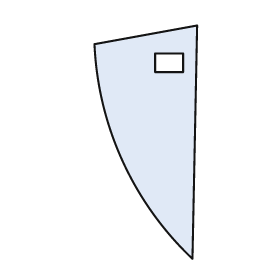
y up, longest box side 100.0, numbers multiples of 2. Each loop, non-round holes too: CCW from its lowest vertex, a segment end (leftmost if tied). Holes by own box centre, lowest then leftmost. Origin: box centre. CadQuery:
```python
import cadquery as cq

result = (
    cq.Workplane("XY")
    .moveTo(20.0, -50.0)
    .lineTo(22.0, 50.0)
    .lineTo(-22.0, 42.0)
    .threePointArc((-10.0, -8.0), (20.0, -50.0))
    .close()
    .moveTo(4.0, 30.0)
    .lineTo(16.0, 30.0)
    .lineTo(16.0, 38.0)
    .lineTo(4.0, 38.0)
    .close()
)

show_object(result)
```